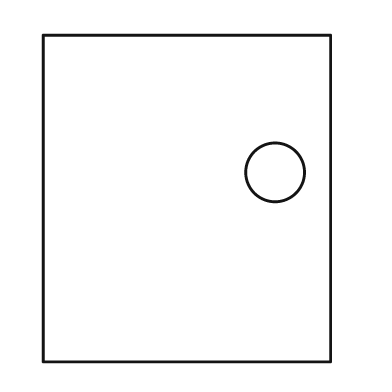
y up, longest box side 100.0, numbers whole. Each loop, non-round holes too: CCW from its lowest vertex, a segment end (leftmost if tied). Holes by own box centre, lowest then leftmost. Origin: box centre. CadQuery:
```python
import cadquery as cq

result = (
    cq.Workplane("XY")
    .moveTo(-44.0, -50.0)
    .lineTo(44.0, -50.0)
    .lineTo(44.0, 50.0)
    .lineTo(-44.0, 50.0)
    .close()
    .moveTo(27.0, 8.0)
    .circle(9.0)
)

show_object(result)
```